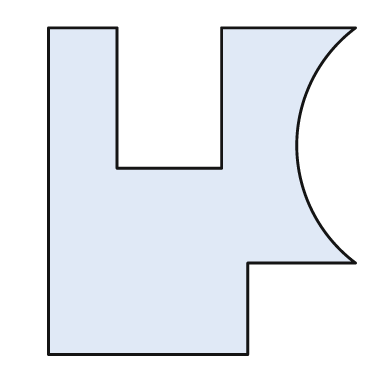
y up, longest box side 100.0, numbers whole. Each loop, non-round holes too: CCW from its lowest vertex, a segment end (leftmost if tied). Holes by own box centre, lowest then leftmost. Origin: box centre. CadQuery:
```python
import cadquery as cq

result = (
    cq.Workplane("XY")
    .moveTo(-47.0, -50.0)
    .lineTo(14.0, -50.0)
    .lineTo(14.0, -22.0)
    .lineTo(47.0, -22.0)
    .threePointArc((29.0, 14.0), (47.0, 50.0))
    .lineTo(6.0, 50.0)
    .lineTo(6.0, 7.0)
    .lineTo(-26.0, 7.0)
    .lineTo(-26.0, 50.0)
    .lineTo(-47.0, 50.0)
    .close()
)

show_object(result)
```